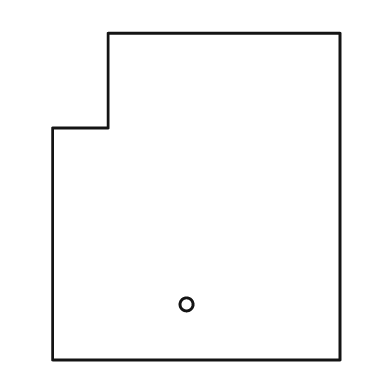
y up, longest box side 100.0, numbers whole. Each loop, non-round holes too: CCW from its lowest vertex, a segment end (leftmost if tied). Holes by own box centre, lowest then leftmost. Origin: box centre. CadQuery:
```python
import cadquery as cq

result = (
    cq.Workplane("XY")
    .moveTo(-44.0, -50.0)
    .lineTo(44.0, -50.0)
    .lineTo(44.0, 50.0)
    .lineTo(-27.0, 50.0)
    .lineTo(-27.0, 21.0)
    .lineTo(-44.0, 21.0)
    .close()
    .moveTo(-3.0, -33.0)
    .circle(2.0)
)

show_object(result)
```